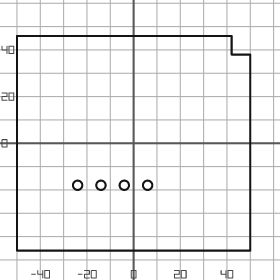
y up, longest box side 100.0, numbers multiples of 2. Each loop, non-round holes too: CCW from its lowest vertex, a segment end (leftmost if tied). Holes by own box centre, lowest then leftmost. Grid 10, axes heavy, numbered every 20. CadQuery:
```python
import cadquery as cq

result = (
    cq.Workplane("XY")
    .moveTo(-50.0, -46.0)
    .lineTo(50.0, -46.0)
    .lineTo(50.0, 38.0)
    .lineTo(42.0, 38.0)
    .lineTo(42.0, 46.0)
    .lineTo(-50.0, 46.0)
    .close()
    .moveTo(-24.0, -18.0)
    .circle(2.0)
    .moveTo(-14.0, -18.0)
    .circle(2.0)
    .moveTo(-4.0, -18.0)
    .circle(2.0)
    .moveTo(6.0, -18.0)
    .circle(2.0)
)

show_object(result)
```